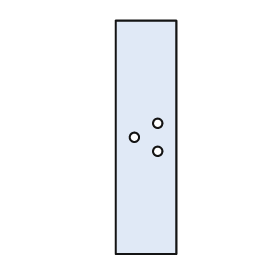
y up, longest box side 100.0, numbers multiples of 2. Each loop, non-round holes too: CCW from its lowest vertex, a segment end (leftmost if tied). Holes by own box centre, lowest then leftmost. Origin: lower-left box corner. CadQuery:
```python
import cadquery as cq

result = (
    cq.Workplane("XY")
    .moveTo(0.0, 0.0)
    .lineTo(26.0, 0.0)
    .lineTo(26.0, 100.0)
    .lineTo(0.0, 100.0)
    .close()
    .moveTo(18.0, 44.0)
    .circle(2.0)
    .moveTo(8.0, 50.0)
    .circle(2.0)
    .moveTo(18.0, 56.0)
    .circle(2.0)
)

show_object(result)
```